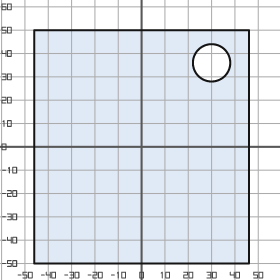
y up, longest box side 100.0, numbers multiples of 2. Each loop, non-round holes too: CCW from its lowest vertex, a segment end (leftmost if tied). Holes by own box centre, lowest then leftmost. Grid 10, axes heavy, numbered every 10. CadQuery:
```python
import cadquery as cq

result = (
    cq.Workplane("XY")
    .moveTo(-46.0, -50.0)
    .lineTo(46.0, -50.0)
    .lineTo(46.0, 50.0)
    .lineTo(-46.0, 50.0)
    .close()
    .moveTo(30.0, 36.0)
    .circle(8.0)
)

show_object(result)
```